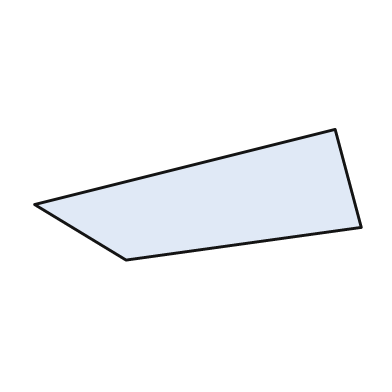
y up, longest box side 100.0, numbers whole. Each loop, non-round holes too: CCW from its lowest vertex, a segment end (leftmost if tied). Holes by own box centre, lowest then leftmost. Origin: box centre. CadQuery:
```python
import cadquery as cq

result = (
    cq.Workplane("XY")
    .moveTo(-22.0, -20.0)
    .lineTo(50.0, -10.0)
    .lineTo(42.0, 20.0)
    .lineTo(-50.0, -3.0)
    .close()
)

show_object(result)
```